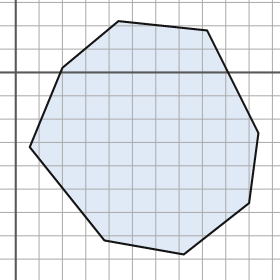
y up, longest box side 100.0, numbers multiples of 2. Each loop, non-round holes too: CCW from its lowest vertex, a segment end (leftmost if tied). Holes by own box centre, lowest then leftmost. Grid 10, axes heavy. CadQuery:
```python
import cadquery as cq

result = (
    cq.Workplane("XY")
    .moveTo(72.0, -78.0)
    .lineTo(100.0, -56.0)
    .lineTo(104.0, -26.0)
    .lineTo(82.0, 18.0)
    .lineTo(44.0, 22.0)
    .lineTo(20.0, 2.0)
    .lineTo(6.0, -32.0)
    .lineTo(38.0, -72.0)
    .close()
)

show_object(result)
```